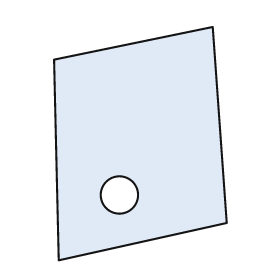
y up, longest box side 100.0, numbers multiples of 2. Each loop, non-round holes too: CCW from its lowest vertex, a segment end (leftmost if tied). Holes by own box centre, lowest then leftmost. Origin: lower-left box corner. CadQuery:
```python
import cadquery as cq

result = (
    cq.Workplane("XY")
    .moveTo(2.0, 0.0)
    .lineTo(74.0, 16.0)
    .lineTo(68.0, 100.0)
    .lineTo(0.0, 86.0)
    .close()
    .moveTo(28.0, 28.0)
    .circle(8.0)
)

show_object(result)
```